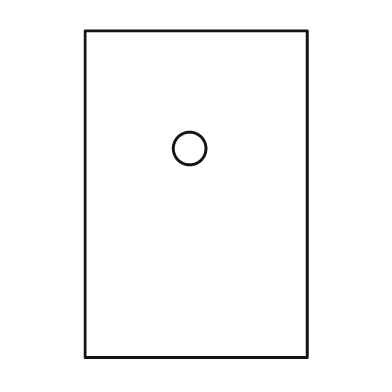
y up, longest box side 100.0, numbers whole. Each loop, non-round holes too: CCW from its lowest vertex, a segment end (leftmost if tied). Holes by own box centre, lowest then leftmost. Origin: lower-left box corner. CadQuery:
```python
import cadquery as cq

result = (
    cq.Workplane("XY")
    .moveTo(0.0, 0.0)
    .lineTo(68.0, 0.0)
    .lineTo(68.0, 100.0)
    .lineTo(0.0, 100.0)
    .close()
    .moveTo(32.0, 64.0)
    .circle(5.0)
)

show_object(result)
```